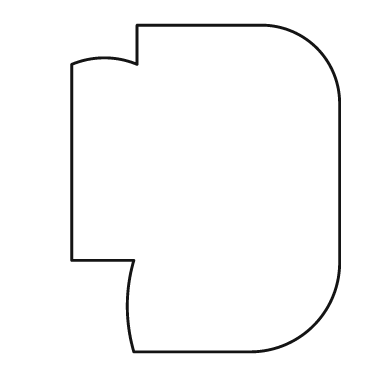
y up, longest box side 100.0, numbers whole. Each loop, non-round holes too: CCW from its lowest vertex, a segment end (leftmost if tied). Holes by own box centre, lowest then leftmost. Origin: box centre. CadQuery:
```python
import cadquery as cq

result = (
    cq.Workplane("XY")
    .moveTo(-22.0, -50.0)
    .lineTo(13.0, -50.0)
    .threePointArc((33.0, -42.0), (41.0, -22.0))
    .lineTo(41.0, 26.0)
    .threePointArc((34.0, 43.0), (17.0, 50.0))
    .lineTo(-21.0, 50.0)
    .lineTo(-21.0, 38.0)
    .threePointArc((-31.0, 40.0), (-41.0, 38.0))
    .lineTo(-41.0, -22.0)
    .lineTo(-22.0, -22.0)
    .threePointArc((-24.0, -36.0), (-22.0, -50.0))
    .close()
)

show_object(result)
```